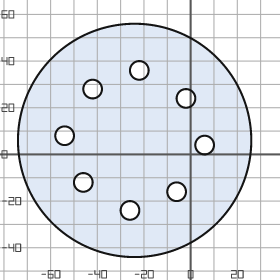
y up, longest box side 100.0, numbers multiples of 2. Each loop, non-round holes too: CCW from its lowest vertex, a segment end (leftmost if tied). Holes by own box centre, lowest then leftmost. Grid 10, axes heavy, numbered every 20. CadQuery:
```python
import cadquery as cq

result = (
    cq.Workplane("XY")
    .moveTo(-24.0, 6.0)
    .circle(50.0)
    .moveTo(-26.0, -24.0)
    .circle(4.0)
    .moveTo(-6.0, -16.0)
    .circle(4.0)
    .moveTo(-46.0, -12.0)
    .circle(4.0)
    .moveTo(6.0, 4.0)
    .circle(4.0)
    .moveTo(-54.0, 8.0)
    .circle(4.0)
    .moveTo(-2.0, 24.0)
    .circle(4.0)
    .moveTo(-42.0, 28.0)
    .circle(4.0)
    .moveTo(-22.0, 36.0)
    .circle(4.0)
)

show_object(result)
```